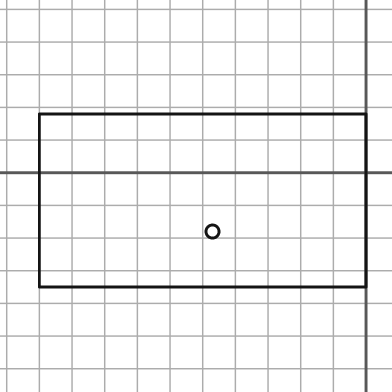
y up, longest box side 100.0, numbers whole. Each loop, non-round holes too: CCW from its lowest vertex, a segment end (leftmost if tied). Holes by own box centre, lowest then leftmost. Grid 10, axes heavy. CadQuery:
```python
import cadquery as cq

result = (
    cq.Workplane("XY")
    .moveTo(-100.0, -35.0)
    .lineTo(0.0, -35.0)
    .lineTo(0.0, 18.0)
    .lineTo(-100.0, 18.0)
    .close()
    .moveTo(-47.0, -18.0)
    .circle(2.0)
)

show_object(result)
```